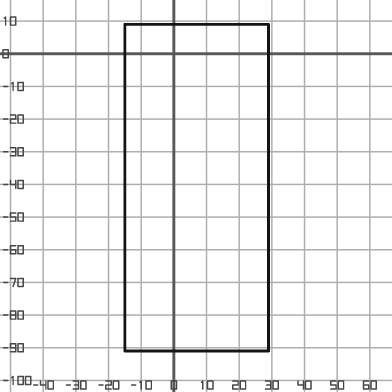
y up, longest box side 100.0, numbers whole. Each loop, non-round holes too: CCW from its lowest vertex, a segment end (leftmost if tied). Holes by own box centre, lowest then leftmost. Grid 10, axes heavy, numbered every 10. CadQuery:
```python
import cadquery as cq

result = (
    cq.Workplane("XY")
    .moveTo(-15.0, -91.0)
    .lineTo(29.0, -91.0)
    .lineTo(29.0, 9.0)
    .lineTo(-15.0, 9.0)
    .close()
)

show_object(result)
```